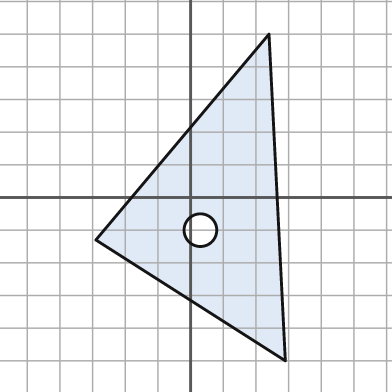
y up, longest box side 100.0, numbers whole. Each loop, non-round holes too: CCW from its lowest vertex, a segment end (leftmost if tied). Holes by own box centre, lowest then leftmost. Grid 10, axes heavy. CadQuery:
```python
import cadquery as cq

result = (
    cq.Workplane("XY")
    .moveTo(29.0, -50.0)
    .lineTo(24.0, 50.0)
    .lineTo(-29.0, -13.0)
    .close()
    .moveTo(3.0, -10.0)
    .circle(5.0)
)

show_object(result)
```